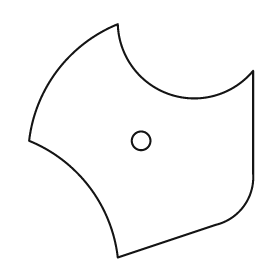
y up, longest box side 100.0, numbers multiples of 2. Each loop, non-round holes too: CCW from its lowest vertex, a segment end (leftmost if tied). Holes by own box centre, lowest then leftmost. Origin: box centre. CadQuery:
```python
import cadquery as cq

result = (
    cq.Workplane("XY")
    .moveTo(-10.0, -50.0)
    .lineTo(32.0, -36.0)
    .threePointArc((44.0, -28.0), (48.0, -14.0))
    .lineTo(48.0, 30.0)
    .threePointArc((12.0, 20.0), (-10.0, 50.0))
    .threePointArc((-36.0, 30.0), (-48.0, 0.0))
    .threePointArc((-22.0, -20.0), (-10.0, -50.0))
    .close()
    .moveTo(0.0, 0.0)
    .circle(4.0)
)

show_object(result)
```